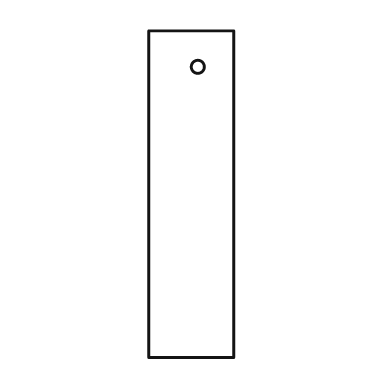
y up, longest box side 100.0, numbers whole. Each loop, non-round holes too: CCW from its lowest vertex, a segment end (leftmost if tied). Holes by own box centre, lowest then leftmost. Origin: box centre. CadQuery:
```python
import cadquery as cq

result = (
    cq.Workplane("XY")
    .moveTo(-13.0, -50.0)
    .lineTo(13.0, -50.0)
    .lineTo(13.0, 50.0)
    .lineTo(-13.0, 50.0)
    .close()
    .moveTo(2.0, 39.0)
    .circle(2.0)
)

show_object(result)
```